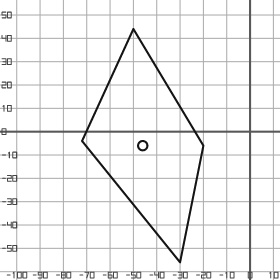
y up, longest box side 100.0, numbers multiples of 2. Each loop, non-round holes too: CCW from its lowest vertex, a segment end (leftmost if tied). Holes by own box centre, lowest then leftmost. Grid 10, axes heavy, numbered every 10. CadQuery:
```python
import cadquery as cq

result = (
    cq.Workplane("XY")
    .moveTo(-30.0, -56.0)
    .lineTo(-20.0, -6.0)
    .lineTo(-50.0, 44.0)
    .lineTo(-72.0, -4.0)
    .close()
    .moveTo(-46.0, -6.0)
    .circle(2.0)
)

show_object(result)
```